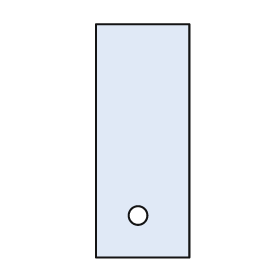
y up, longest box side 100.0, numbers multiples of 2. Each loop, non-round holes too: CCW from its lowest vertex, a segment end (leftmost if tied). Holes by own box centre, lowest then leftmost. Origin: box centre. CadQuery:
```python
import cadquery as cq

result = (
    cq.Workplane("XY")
    .moveTo(-20.0, -50.0)
    .lineTo(20.0, -50.0)
    .lineTo(20.0, 50.0)
    .lineTo(-20.0, 50.0)
    .close()
    .moveTo(-2.0, -32.0)
    .circle(4.0)
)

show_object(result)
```